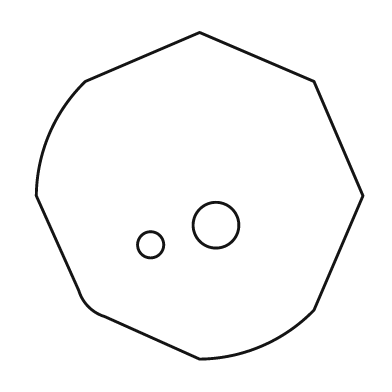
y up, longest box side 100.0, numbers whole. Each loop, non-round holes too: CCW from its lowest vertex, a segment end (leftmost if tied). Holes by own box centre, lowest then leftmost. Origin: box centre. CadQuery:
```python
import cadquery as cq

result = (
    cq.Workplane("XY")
    .moveTo(0.0, -50.0)
    .threePointArc((19.0, -46.0), (35.0, -35.0))
    .lineTo(50.0, 0.0)
    .lineTo(35.0, 35.0)
    .lineTo(0.0, 50.0)
    .lineTo(-35.0, 35.0)
    .threePointArc((-46.0, 19.0), (-50.0, 0.0))
    .lineTo(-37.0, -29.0)
    .threePointArc((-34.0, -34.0), (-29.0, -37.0))
    .close()
    .moveTo(-15.0, -15.0)
    .circle(4.0)
    .moveTo(5.0, -9.0)
    .circle(7.0)
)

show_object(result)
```